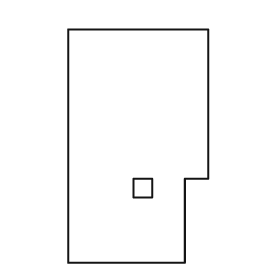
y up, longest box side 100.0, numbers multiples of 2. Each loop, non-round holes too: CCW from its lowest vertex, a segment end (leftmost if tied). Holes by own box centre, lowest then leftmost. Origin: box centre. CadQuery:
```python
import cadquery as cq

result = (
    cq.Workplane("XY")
    .moveTo(-30.0, -50.0)
    .lineTo(20.0, -50.0)
    .lineTo(20.0, -14.0)
    .lineTo(30.0, -14.0)
    .lineTo(30.0, 50.0)
    .lineTo(-30.0, 50.0)
    .close()
    .moveTo(-2.0, -22.0)
    .lineTo(6.0, -22.0)
    .lineTo(6.0, -14.0)
    .lineTo(-2.0, -14.0)
    .close()
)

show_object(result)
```